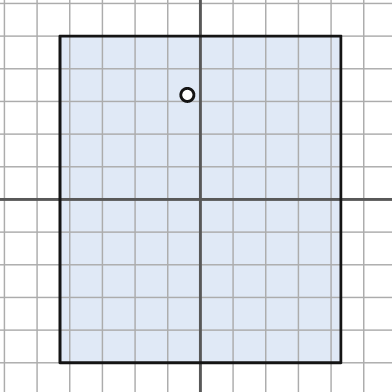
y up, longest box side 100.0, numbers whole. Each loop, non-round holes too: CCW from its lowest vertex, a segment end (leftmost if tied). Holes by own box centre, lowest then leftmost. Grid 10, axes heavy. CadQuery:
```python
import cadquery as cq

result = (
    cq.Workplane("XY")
    .moveTo(-43.0, -50.0)
    .lineTo(43.0, -50.0)
    .lineTo(43.0, 50.0)
    .lineTo(-43.0, 50.0)
    .close()
    .moveTo(-4.0, 32.0)
    .circle(2.0)
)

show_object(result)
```